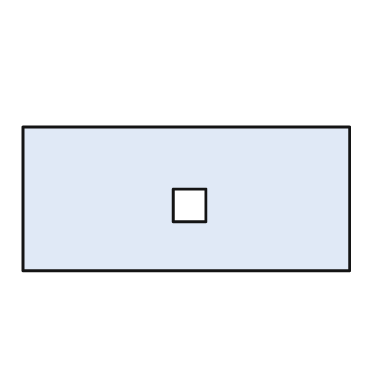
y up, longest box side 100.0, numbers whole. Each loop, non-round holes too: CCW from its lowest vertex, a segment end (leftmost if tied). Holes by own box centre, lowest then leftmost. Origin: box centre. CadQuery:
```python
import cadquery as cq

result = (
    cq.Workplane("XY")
    .moveTo(-50.0, -22.0)
    .lineTo(50.0, -22.0)
    .lineTo(50.0, 22.0)
    .lineTo(-50.0, 22.0)
    .close()
    .moveTo(-4.0, -7.0)
    .lineTo(6.0, -7.0)
    .lineTo(6.0, 3.0)
    .lineTo(-4.0, 3.0)
    .close()
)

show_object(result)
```